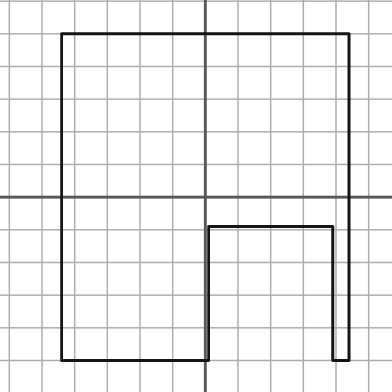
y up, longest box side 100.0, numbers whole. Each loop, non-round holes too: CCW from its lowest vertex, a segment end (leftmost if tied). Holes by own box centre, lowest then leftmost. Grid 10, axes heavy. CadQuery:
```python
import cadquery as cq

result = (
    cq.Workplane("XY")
    .moveTo(-44.0, -50.0)
    .lineTo(1.0, -50.0)
    .lineTo(1.0, -9.0)
    .lineTo(39.0, -9.0)
    .lineTo(39.0, -50.0)
    .lineTo(44.0, -50.0)
    .lineTo(44.0, 50.0)
    .lineTo(-44.0, 50.0)
    .close()
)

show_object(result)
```